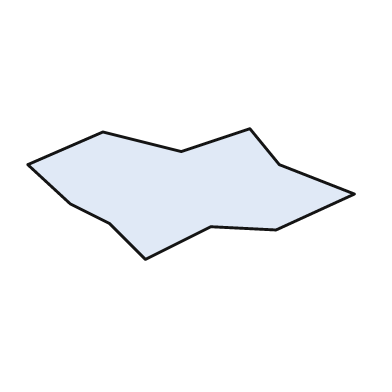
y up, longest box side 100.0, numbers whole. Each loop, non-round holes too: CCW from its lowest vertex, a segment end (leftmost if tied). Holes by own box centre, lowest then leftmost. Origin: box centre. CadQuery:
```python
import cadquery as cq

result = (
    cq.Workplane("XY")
    .moveTo(-14.0, -20.0)
    .lineTo(6.0, -10.0)
    .lineTo(26.0, -11.0)
    .lineTo(50.0, 0.0)
    .lineTo(27.0, 9.0)
    .lineTo(18.0, 20.0)
    .lineTo(-3.0, 13.0)
    .lineTo(-27.0, 19.0)
    .lineTo(-50.0, 9.0)
    .lineTo(-37.0, -3.0)
    .lineTo(-25.0, -9.0)
    .close()
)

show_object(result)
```